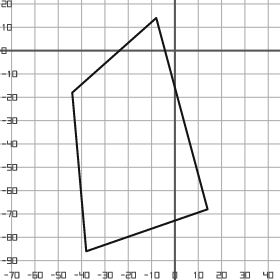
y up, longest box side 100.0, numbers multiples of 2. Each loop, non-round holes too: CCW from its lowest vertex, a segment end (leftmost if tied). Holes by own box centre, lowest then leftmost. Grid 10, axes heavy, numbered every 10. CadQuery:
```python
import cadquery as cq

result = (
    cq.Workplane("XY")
    .moveTo(-38.0, -86.0)
    .lineTo(14.0, -68.0)
    .lineTo(-8.0, 14.0)
    .lineTo(-44.0, -18.0)
    .close()
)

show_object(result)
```